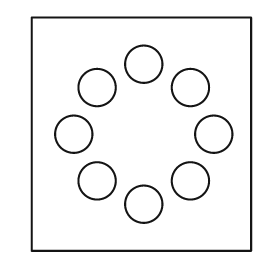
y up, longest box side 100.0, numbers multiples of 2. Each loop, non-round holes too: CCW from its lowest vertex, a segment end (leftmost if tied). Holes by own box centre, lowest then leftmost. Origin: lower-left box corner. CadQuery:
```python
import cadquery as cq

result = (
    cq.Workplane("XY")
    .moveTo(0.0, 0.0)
    .lineTo(94.0, 0.0)
    .lineTo(94.0, 100.0)
    .lineTo(0.0, 100.0)
    .close()
    .moveTo(48.0, 20.0)
    .circle(8.0)
    .moveTo(28.0, 30.0)
    .circle(8.0)
    .moveTo(68.0, 30.0)
    .circle(8.0)
    .moveTo(18.0, 50.0)
    .circle(8.0)
    .moveTo(78.0, 50.0)
    .circle(8.0)
    .moveTo(28.0, 70.0)
    .circle(8.0)
    .moveTo(68.0, 70.0)
    .circle(8.0)
    .moveTo(48.0, 80.0)
    .circle(8.0)
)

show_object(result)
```